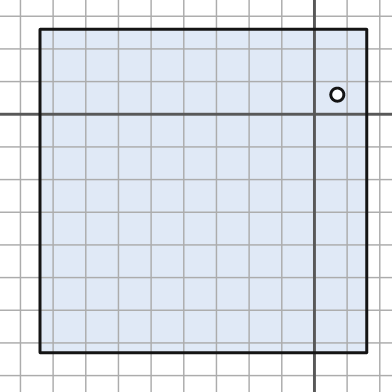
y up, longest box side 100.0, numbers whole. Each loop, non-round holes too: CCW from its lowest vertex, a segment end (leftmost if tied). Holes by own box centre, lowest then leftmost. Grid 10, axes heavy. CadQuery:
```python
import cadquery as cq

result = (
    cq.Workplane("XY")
    .moveTo(-84.0, -73.0)
    .lineTo(16.0, -73.0)
    .lineTo(16.0, 26.0)
    .lineTo(-84.0, 26.0)
    .close()
    .moveTo(7.0, 6.0)
    .circle(2.0)
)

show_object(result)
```